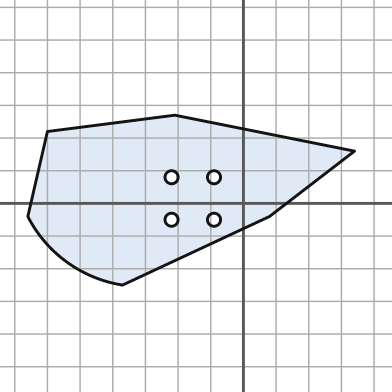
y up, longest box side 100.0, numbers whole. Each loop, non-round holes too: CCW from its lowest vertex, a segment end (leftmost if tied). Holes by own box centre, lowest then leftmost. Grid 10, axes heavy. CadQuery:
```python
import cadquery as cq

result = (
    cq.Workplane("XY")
    .moveTo(-37.0, -25.0)
    .lineTo(8.0, -4.0)
    .lineTo(34.0, 16.0)
    .lineTo(-21.0, 27.0)
    .lineTo(-60.0, 22.0)
    .lineTo(-66.0, -4.0)
    .threePointArc((-54.0, -18.0), (-37.0, -25.0))
    .close()
    .moveTo(-22.0, -5.0)
    .circle(2.0)
    .moveTo(-9.0, -5.0)
    .circle(2.0)
    .moveTo(-22.0, 8.0)
    .circle(2.0)
    .moveTo(-9.0, 8.0)
    .circle(2.0)
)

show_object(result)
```